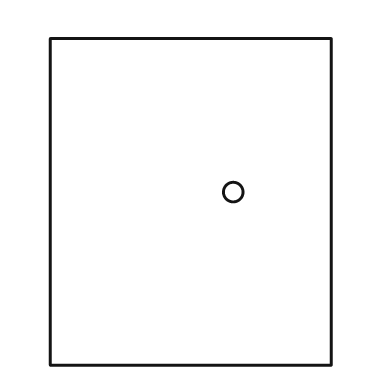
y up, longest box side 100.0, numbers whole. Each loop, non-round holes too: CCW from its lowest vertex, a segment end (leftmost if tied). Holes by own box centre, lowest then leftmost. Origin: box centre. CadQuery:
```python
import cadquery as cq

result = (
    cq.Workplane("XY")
    .moveTo(-43.0, -50.0)
    .lineTo(43.0, -50.0)
    .lineTo(43.0, 50.0)
    .lineTo(-43.0, 50.0)
    .close()
    .moveTo(13.0, 3.0)
    .circle(3.0)
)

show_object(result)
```